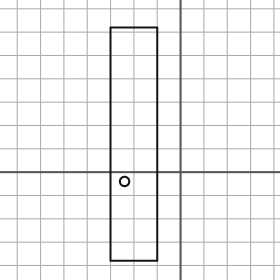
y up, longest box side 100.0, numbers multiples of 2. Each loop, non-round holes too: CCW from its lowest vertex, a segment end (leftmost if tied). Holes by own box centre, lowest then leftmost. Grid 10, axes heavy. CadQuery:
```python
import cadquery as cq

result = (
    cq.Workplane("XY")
    .moveTo(-30.0, -38.0)
    .lineTo(-10.0, -38.0)
    .lineTo(-10.0, 62.0)
    .lineTo(-30.0, 62.0)
    .close()
    .moveTo(-24.0, -4.0)
    .circle(2.0)
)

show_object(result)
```